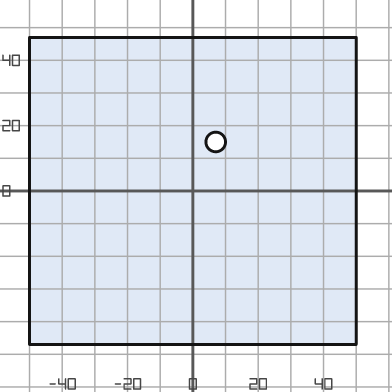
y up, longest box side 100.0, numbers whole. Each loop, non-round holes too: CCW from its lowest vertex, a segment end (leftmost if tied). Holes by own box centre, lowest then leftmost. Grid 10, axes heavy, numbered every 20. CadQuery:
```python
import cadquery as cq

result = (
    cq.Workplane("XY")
    .moveTo(-50.0, -47.0)
    .lineTo(50.0, -47.0)
    .lineTo(50.0, 47.0)
    .lineTo(-50.0, 47.0)
    .close()
    .moveTo(7.0, 15.0)
    .circle(3.0)
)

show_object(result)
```